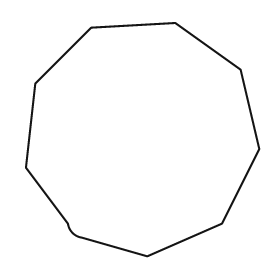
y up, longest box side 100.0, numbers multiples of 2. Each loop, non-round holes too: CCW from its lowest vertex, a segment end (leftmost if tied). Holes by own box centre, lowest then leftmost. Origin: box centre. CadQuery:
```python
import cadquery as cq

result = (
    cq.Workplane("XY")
    .moveTo(2.0, -50.0)
    .lineTo(34.0, -36.0)
    .lineTo(50.0, -4.0)
    .lineTo(42.0, 30.0)
    .lineTo(14.0, 50.0)
    .lineTo(-22.0, 48.0)
    .lineTo(-46.0, 24.0)
    .lineTo(-50.0, -12.0)
    .lineTo(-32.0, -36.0)
    .threePointArc((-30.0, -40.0), (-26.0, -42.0))
    .close()
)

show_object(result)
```